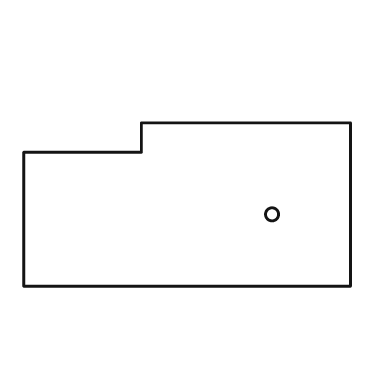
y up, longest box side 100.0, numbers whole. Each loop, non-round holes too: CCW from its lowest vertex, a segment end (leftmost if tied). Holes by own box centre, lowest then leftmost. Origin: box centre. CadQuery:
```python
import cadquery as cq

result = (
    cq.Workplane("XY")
    .moveTo(-50.0, -25.0)
    .lineTo(50.0, -25.0)
    .lineTo(50.0, 25.0)
    .lineTo(-14.0, 25.0)
    .lineTo(-14.0, 16.0)
    .lineTo(-50.0, 16.0)
    .close()
    .moveTo(26.0, -3.0)
    .circle(2.0)
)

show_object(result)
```